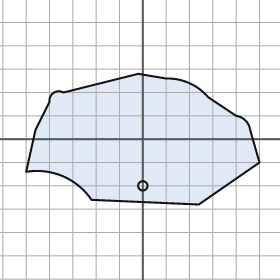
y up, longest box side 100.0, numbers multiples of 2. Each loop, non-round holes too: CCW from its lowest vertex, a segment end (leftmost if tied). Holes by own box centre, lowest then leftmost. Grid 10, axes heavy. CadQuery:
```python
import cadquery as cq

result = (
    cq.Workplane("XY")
    .moveTo(24.0, -28.0)
    .lineTo(50.0, -10.0)
    .lineTo(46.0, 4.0)
    .threePointArc((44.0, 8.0), (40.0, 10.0))
    .lineTo(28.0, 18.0)
    .threePointArc((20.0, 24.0), (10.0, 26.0))
    .lineTo(-2.0, 28.0)
    .lineTo(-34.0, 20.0)
    .threePointArc((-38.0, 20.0), (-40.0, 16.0))
    .lineTo(-46.0, 4.0)
    .lineTo(-50.0, -14.0)
    .threePointArc((-34.0, -16.0), (-22.0, -26.0))
    .close()
    .moveTo(0.0, -20.0)
    .circle(2.0)
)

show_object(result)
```